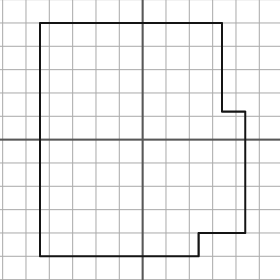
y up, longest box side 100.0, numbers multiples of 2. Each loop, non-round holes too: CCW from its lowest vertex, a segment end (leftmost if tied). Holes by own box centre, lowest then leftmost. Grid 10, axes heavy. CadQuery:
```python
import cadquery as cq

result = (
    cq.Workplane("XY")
    .moveTo(-44.0, -50.0)
    .lineTo(24.0, -50.0)
    .lineTo(24.0, -40.0)
    .lineTo(44.0, -40.0)
    .lineTo(44.0, 12.0)
    .lineTo(34.0, 12.0)
    .lineTo(34.0, 50.0)
    .lineTo(-44.0, 50.0)
    .close()
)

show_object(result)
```